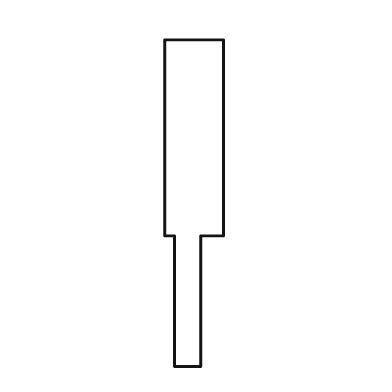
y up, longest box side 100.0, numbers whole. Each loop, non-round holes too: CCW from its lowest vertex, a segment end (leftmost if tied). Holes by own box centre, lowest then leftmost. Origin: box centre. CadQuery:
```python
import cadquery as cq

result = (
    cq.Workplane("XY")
    .moveTo(-6.0, -50.0)
    .lineTo(2.0, -50.0)
    .lineTo(2.0, -10.0)
    .lineTo(9.0, -10.0)
    .lineTo(9.0, 50.0)
    .lineTo(-9.0, 50.0)
    .lineTo(-9.0, -10.0)
    .lineTo(-6.0, -10.0)
    .close()
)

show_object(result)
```